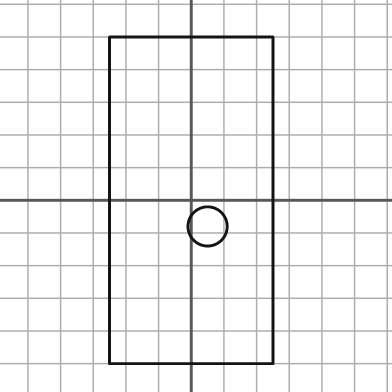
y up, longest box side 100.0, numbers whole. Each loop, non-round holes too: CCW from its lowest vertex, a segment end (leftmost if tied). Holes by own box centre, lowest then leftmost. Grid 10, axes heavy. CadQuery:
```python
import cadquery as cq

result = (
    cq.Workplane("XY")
    .moveTo(-25.0, -50.0)
    .lineTo(25.0, -50.0)
    .lineTo(25.0, 50.0)
    .lineTo(-25.0, 50.0)
    .close()
    .moveTo(5.0, -8.0)
    .circle(6.0)
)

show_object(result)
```